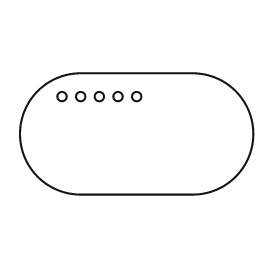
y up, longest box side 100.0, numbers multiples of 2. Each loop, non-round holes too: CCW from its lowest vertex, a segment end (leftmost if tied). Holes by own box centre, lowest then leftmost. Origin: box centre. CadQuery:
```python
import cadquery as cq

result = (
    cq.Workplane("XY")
    .moveTo(-24.0, -26.0)
    .lineTo(24.0, -26.0)
    .threePointArc((50.0, 0.0), (24.0, 26.0))
    .lineTo(-24.0, 26.0)
    .threePointArc((-50.0, 0.0), (-24.0, -26.0))
    .close()
    .moveTo(-32.0, 16.0)
    .circle(2.0)
    .moveTo(-24.0, 16.0)
    .circle(2.0)
    .moveTo(-16.0, 16.0)
    .circle(2.0)
    .moveTo(-8.0, 16.0)
    .circle(2.0)
    .moveTo(0.0, 16.0)
    .circle(2.0)
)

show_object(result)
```